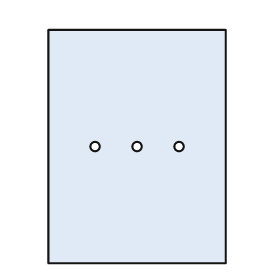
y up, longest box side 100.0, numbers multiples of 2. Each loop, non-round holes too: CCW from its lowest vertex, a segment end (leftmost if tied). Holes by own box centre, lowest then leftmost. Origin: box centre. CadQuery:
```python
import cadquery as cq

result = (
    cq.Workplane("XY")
    .moveTo(-38.0, -50.0)
    .lineTo(38.0, -50.0)
    .lineTo(38.0, 50.0)
    .lineTo(-38.0, 50.0)
    .close()
    .moveTo(-18.0, 0.0)
    .circle(2.0)
    .moveTo(0.0, 0.0)
    .circle(2.0)
    .moveTo(18.0, 0.0)
    .circle(2.0)
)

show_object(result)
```